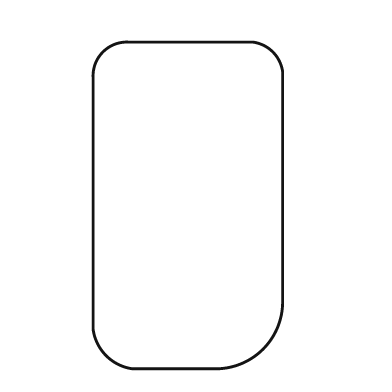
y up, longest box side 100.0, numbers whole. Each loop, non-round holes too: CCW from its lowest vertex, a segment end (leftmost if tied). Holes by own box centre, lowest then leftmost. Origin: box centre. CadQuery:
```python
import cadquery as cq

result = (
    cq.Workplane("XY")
    .moveTo(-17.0, -50.0)
    .lineTo(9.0, -50.0)
    .threePointArc((23.0, -44.0), (29.0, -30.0))
    .lineTo(29.0, 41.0)
    .threePointArc((26.0, 47.0), (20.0, 50.0))
    .lineTo(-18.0, 50.0)
    .threePointArc((-26.0, 47.0), (-29.0, 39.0))
    .lineTo(-29.0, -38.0)
    .threePointArc((-25.0, -46.0), (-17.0, -50.0))
    .close()
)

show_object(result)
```